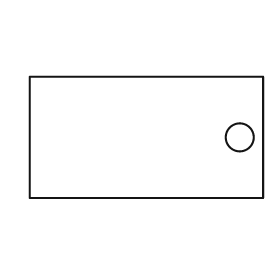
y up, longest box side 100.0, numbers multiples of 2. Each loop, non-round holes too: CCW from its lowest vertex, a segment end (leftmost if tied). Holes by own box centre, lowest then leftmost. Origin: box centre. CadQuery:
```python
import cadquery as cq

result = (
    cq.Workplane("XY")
    .moveTo(-50.0, -26.0)
    .lineTo(50.0, -26.0)
    .lineTo(50.0, 26.0)
    .lineTo(-50.0, 26.0)
    .close()
    .moveTo(40.0, 0.0)
    .circle(6.0)
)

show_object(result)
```